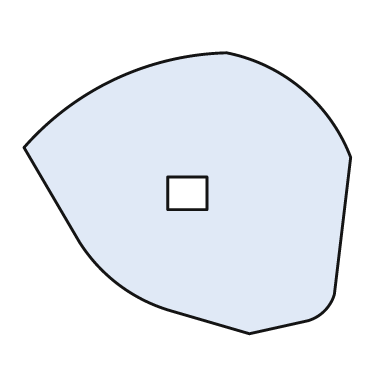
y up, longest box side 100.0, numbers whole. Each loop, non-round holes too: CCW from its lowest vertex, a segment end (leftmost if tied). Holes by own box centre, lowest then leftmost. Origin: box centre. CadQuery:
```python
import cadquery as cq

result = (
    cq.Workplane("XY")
    .moveTo(19.0, -43.0)
    .lineTo(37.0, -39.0)
    .threePointArc((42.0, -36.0), (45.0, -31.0))
    .lineTo(50.0, 11.0)
    .threePointArc((35.0, 32.0), (12.0, 43.0))
    .threePointArc((-22.0, 35.0), (-50.0, 14.0))
    .lineTo(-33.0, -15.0)
    .threePointArc((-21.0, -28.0), (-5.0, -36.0))
    .close()
    .moveTo(-6.0, -5.0)
    .lineTo(6.0, -5.0)
    .lineTo(6.0, 5.0)
    .lineTo(-6.0, 5.0)
    .close()
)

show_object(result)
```